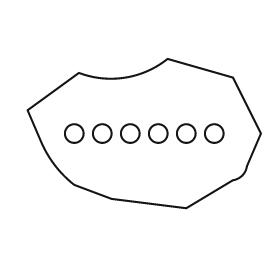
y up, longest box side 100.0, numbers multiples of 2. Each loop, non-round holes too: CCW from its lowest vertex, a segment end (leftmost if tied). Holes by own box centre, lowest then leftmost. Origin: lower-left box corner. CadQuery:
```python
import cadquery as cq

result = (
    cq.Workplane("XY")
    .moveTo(68.0, 0.0)
    .lineTo(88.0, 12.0)
    .threePointArc((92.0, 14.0), (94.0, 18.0))
    .lineTo(100.0, 32.0)
    .lineTo(88.0, 56.0)
    .lineTo(60.0, 64.0)
    .threePointArc((42.0, 56.0), (22.0, 58.0))
    .lineTo(0.0, 42.0)
    .lineTo(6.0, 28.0)
    .threePointArc((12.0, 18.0), (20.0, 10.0))
    .lineTo(36.0, 4.0)
    .close()
    .moveTo(20.0, 32.0)
    .circle(4.0)
    .moveTo(32.0, 32.0)
    .circle(4.0)
    .moveTo(44.0, 32.0)
    .circle(4.0)
    .moveTo(56.0, 32.0)
    .circle(4.0)
    .moveTo(68.0, 32.0)
    .circle(4.0)
    .moveTo(80.0, 32.0)
    .circle(4.0)
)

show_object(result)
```